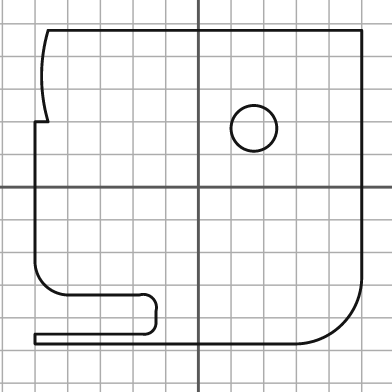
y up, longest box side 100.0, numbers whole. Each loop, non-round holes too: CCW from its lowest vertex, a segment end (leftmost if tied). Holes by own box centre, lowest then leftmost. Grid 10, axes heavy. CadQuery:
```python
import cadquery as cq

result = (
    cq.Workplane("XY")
    .moveTo(-50.0, -48.0)
    .lineTo(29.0, -48.0)
    .threePointArc((44.0, -42.0), (50.0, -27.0))
    .lineTo(50.0, 48.0)
    .lineTo(-46.0, 48.0)
    .threePointArc((-48.0, 34.0), (-46.0, 20.0))
    .lineTo(-50.0, 20.0)
    .lineTo(-50.0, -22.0)
    .threePointArc((-47.0, -30.0), (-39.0, -33.0))
    .lineTo(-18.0, -33.0)
    .threePointArc((-14.0, -34.0), (-13.0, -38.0))
    .lineTo(-13.0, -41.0)
    .threePointArc((-14.0, -44.0), (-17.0, -45.0))
    .lineTo(-50.0, -45.0)
    .close()
    .moveTo(17.0, 18.0)
    .circle(7.0)
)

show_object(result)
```